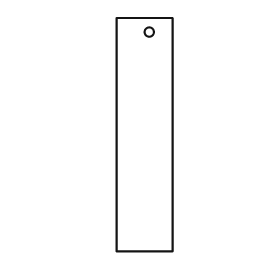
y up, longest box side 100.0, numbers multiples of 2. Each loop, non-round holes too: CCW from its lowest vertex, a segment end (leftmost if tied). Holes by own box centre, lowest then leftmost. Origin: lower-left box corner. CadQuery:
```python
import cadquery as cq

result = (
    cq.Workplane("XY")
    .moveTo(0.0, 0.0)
    .lineTo(24.0, 0.0)
    .lineTo(24.0, 100.0)
    .lineTo(0.0, 100.0)
    .close()
    .moveTo(14.0, 94.0)
    .circle(2.0)
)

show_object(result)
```